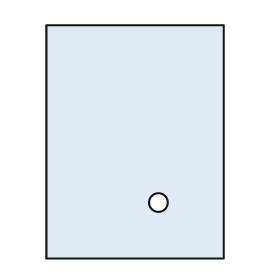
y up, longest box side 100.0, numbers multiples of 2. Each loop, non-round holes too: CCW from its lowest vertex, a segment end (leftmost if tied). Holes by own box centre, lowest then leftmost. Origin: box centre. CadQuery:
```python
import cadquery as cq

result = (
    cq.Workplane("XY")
    .moveTo(-38.0, -50.0)
    .lineTo(38.0, -50.0)
    .lineTo(38.0, 50.0)
    .lineTo(-38.0, 50.0)
    .close()
    .moveTo(10.0, -26.0)
    .circle(4.0)
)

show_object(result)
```